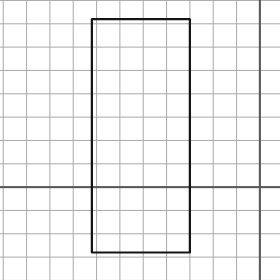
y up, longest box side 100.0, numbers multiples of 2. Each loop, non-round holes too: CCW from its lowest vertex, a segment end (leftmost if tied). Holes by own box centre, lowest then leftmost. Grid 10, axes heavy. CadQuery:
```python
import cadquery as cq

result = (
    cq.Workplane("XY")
    .moveTo(-72.0, -28.0)
    .lineTo(-30.0, -28.0)
    .lineTo(-30.0, 72.0)
    .lineTo(-72.0, 72.0)
    .close()
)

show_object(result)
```